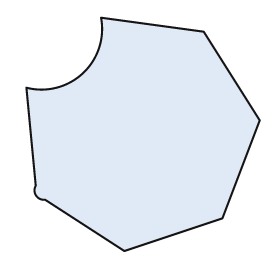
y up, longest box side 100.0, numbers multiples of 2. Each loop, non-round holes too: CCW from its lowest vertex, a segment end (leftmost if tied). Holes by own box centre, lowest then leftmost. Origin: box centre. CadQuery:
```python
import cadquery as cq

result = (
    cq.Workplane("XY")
    .moveTo(-8.0, -50.0)
    .lineTo(34.0, -36.0)
    .lineTo(50.0, 6.0)
    .lineTo(26.0, 44.0)
    .lineTo(-18.0, 50.0)
    .threePointArc((-26.0, 26.0), (-50.0, 20.0))
    .lineTo(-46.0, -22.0)
    .threePointArc((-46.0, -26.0), (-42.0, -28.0))
    .close()
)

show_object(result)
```